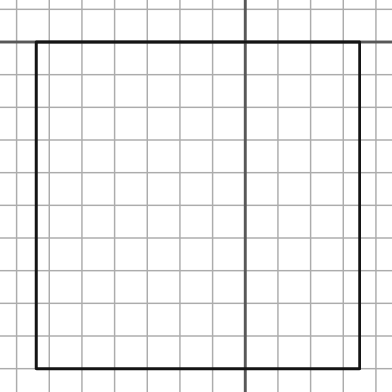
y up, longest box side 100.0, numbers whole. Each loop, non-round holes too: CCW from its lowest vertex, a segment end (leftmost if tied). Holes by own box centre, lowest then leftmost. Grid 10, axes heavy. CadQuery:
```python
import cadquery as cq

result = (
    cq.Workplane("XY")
    .moveTo(-64.0, -100.0)
    .lineTo(35.0, -100.0)
    .lineTo(35.0, 0.0)
    .lineTo(-64.0, 0.0)
    .close()
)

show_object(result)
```